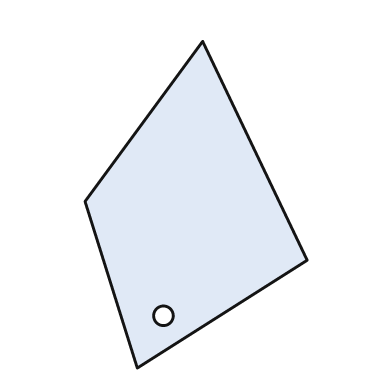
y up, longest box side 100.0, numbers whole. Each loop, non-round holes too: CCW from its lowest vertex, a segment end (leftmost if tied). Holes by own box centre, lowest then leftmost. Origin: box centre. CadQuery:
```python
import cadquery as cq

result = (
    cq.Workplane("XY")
    .moveTo(-18.0, -50.0)
    .lineTo(34.0, -17.0)
    .lineTo(2.0, 50.0)
    .lineTo(-34.0, 1.0)
    .close()
    .moveTo(-10.0, -34.0)
    .circle(3.0)
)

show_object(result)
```